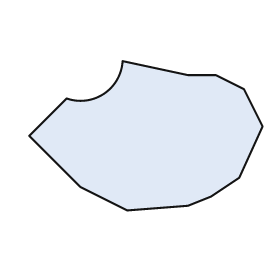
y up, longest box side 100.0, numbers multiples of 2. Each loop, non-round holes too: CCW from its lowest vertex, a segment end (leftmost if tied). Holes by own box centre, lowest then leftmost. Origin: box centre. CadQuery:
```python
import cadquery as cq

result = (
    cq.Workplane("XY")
    .moveTo(-8.0, -32.0)
    .lineTo(18.0, -30.0)
    .lineTo(28.0, -26.0)
    .lineTo(40.0, -18.0)
    .lineTo(50.0, 4.0)
    .lineTo(42.0, 20.0)
    .lineTo(30.0, 26.0)
    .lineTo(18.0, 26.0)
    .lineTo(-10.0, 32.0)
    .threePointArc((-18.0, 18.0), (-34.0, 16.0))
    .lineTo(-50.0, 0.0)
    .lineTo(-28.0, -22.0)
    .close()
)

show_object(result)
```